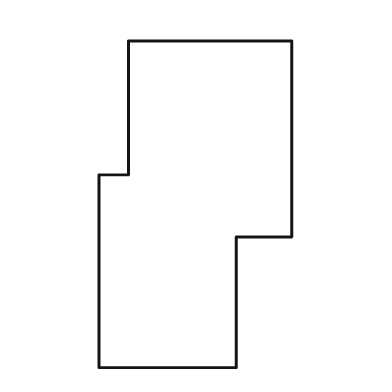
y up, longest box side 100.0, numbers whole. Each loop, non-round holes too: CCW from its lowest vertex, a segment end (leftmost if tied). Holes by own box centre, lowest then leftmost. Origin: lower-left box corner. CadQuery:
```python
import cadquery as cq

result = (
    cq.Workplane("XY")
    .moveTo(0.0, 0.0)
    .lineTo(42.0, 0.0)
    .lineTo(42.0, 40.0)
    .lineTo(59.0, 40.0)
    .lineTo(59.0, 100.0)
    .lineTo(9.0, 100.0)
    .lineTo(9.0, 59.0)
    .lineTo(0.0, 59.0)
    .close()
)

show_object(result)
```